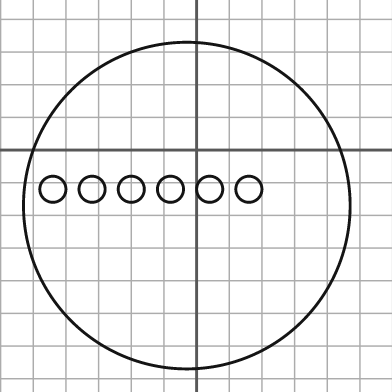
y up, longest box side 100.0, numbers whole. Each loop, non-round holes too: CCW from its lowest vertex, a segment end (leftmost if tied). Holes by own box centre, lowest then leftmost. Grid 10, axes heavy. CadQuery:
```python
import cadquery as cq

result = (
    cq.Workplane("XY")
    .moveTo(-3.0, -17.0)
    .circle(50.0)
    .moveTo(-44.0, -12.0)
    .circle(4.0)
    .moveTo(-32.0, -12.0)
    .circle(4.0)
    .moveTo(-20.0, -12.0)
    .circle(4.0)
    .moveTo(-8.0, -12.0)
    .circle(4.0)
    .moveTo(4.0, -12.0)
    .circle(4.0)
    .moveTo(16.0, -12.0)
    .circle(4.0)
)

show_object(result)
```